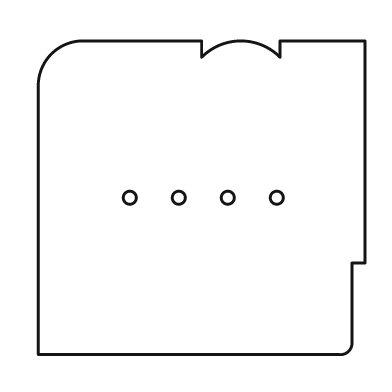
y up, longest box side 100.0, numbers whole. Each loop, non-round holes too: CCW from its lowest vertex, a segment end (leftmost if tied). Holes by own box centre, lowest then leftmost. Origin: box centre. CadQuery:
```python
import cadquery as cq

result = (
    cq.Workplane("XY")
    .moveTo(-50.0, -48.0)
    .lineTo(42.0, -48.0)
    .threePointArc((45.0, -47.0), (46.0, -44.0))
    .lineTo(46.0, -20.0)
    .lineTo(50.0, -20.0)
    .lineTo(50.0, 48.0)
    .lineTo(24.0, 48.0)
    .lineTo(24.0, 43.0)
    .threePointArc((12.0, 48.0), (0.0, 43.0))
    .lineTo(0.0, 48.0)
    .lineTo(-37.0, 48.0)
    .threePointArc((-46.0, 44.0), (-50.0, 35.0))
    .close()
    .moveTo(-22.0, 0.0)
    .circle(2.0)
    .moveTo(-7.0, 0.0)
    .circle(2.0)
    .moveTo(8.0, 0.0)
    .circle(2.0)
    .moveTo(23.0, 0.0)
    .circle(2.0)
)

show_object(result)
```